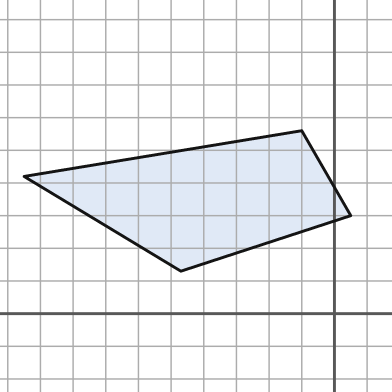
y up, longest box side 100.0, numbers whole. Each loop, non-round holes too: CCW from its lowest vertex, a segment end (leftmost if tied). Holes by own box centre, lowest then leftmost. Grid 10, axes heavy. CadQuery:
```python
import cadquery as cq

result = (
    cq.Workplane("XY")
    .moveTo(-47.0, 13.0)
    .lineTo(5.0, 30.0)
    .lineTo(-10.0, 56.0)
    .lineTo(-95.0, 42.0)
    .close()
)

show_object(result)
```